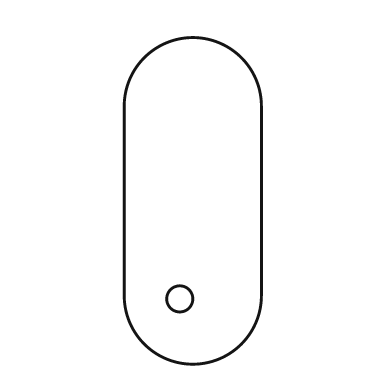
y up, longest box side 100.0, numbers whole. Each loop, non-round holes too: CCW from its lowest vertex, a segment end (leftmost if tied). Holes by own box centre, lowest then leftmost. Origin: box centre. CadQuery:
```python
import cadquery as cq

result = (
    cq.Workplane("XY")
    .moveTo(-21.0, -29.0)
    .threePointArc((0.0, -50.0), (21.0, -29.0))
    .lineTo(21.0, 29.0)
    .threePointArc((0.0, 50.0), (-21.0, 29.0))
    .close()
    .moveTo(-4.0, -30.0)
    .circle(4.0)
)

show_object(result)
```